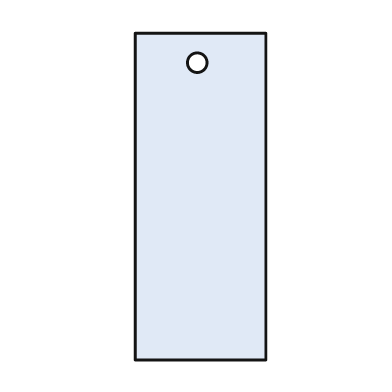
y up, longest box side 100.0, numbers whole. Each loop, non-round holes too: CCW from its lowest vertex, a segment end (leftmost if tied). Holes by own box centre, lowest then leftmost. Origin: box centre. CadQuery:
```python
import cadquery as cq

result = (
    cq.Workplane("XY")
    .moveTo(-20.0, -50.0)
    .lineTo(20.0, -50.0)
    .lineTo(20.0, 50.0)
    .lineTo(-20.0, 50.0)
    .close()
    .moveTo(-1.0, 41.0)
    .circle(3.0)
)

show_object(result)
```